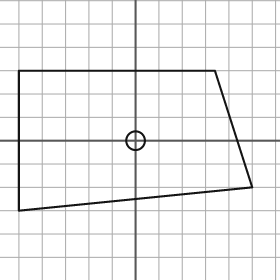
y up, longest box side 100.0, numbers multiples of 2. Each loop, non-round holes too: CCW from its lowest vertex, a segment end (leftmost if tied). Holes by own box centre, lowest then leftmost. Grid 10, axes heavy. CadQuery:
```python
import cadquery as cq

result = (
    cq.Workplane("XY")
    .moveTo(-50.0, -30.0)
    .lineTo(50.0, -20.0)
    .lineTo(34.0, 30.0)
    .lineTo(-50.0, 30.0)
    .close()
    .moveTo(0.0, 0.0)
    .circle(4.0)
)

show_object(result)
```